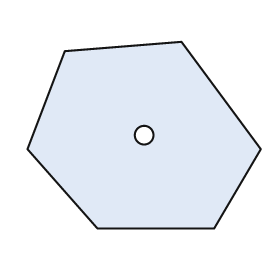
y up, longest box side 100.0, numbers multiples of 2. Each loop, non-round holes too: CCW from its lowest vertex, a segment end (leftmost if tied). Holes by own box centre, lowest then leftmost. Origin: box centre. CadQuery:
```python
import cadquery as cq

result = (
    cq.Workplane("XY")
    .moveTo(-20.0, -40.0)
    .lineTo(30.0, -40.0)
    .lineTo(50.0, -6.0)
    .lineTo(16.0, 40.0)
    .lineTo(-34.0, 36.0)
    .lineTo(-50.0, -6.0)
    .close()
    .moveTo(0.0, 0.0)
    .circle(4.0)
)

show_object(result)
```